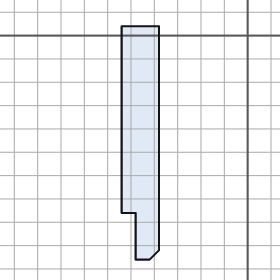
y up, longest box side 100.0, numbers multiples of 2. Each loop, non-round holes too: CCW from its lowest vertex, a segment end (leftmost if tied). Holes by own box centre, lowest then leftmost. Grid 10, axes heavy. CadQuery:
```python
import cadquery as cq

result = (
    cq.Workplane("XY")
    .moveTo(-48.0, -96.0)
    .lineTo(-42.0, -96.0)
    .lineTo(-38.0, -92.0)
    .lineTo(-38.0, 4.0)
    .lineTo(-54.0, 4.0)
    .lineTo(-54.0, -76.0)
    .lineTo(-48.0, -76.0)
    .close()
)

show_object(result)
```